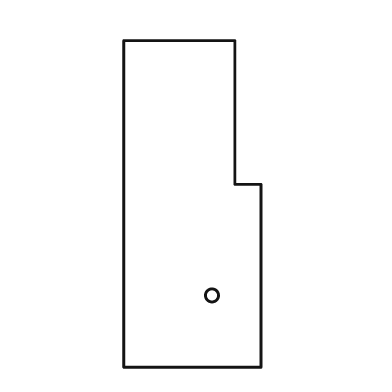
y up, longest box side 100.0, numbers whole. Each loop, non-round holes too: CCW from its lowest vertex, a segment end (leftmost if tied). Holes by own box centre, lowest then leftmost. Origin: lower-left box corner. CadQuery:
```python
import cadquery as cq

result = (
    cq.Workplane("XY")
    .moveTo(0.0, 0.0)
    .lineTo(42.0, 0.0)
    .lineTo(42.0, 56.0)
    .lineTo(34.0, 56.0)
    .lineTo(34.0, 100.0)
    .lineTo(0.0, 100.0)
    .close()
    .moveTo(27.0, 22.0)
    .circle(2.0)
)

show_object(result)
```